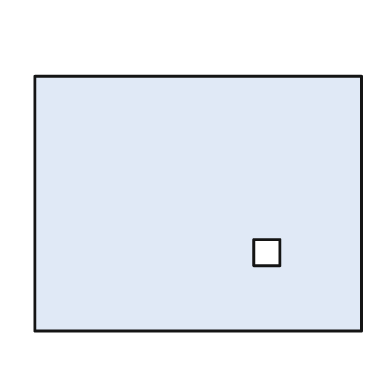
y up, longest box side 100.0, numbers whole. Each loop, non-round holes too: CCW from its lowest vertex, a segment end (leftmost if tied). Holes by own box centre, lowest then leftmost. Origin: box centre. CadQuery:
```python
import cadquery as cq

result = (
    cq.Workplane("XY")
    .moveTo(-50.0, -39.0)
    .lineTo(50.0, -39.0)
    .lineTo(50.0, 39.0)
    .lineTo(-50.0, 39.0)
    .close()
    .moveTo(17.0, -19.0)
    .lineTo(25.0, -19.0)
    .lineTo(25.0, -11.0)
    .lineTo(17.0, -11.0)
    .close()
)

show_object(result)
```